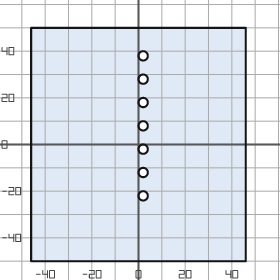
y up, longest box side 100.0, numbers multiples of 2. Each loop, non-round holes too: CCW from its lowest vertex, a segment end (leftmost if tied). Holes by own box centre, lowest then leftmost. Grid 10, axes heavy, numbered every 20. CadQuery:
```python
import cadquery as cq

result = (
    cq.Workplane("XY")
    .moveTo(-46.0, -50.0)
    .lineTo(46.0, -50.0)
    .lineTo(46.0, 50.0)
    .lineTo(-46.0, 50.0)
    .close()
    .moveTo(2.0, -22.0)
    .circle(2.0)
    .moveTo(2.0, -12.0)
    .circle(2.0)
    .moveTo(2.0, -2.0)
    .circle(2.0)
    .moveTo(2.0, 8.0)
    .circle(2.0)
    .moveTo(2.0, 18.0)
    .circle(2.0)
    .moveTo(2.0, 28.0)
    .circle(2.0)
    .moveTo(2.0, 38.0)
    .circle(2.0)
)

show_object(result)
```